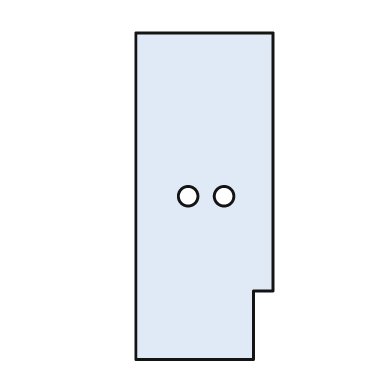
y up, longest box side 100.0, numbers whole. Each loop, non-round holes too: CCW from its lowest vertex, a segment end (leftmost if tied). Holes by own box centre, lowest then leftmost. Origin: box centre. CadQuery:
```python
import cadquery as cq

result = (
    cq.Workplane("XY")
    .moveTo(-21.0, -50.0)
    .lineTo(15.0, -50.0)
    .lineTo(15.0, -29.0)
    .lineTo(21.0, -29.0)
    .lineTo(21.0, 50.0)
    .lineTo(-21.0, 50.0)
    .close()
    .moveTo(-5.0, 0.0)
    .circle(3.0)
    .moveTo(6.0, 0.0)
    .circle(3.0)
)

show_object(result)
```